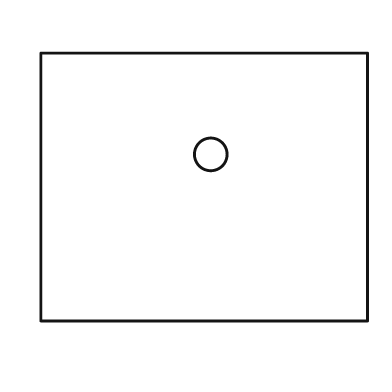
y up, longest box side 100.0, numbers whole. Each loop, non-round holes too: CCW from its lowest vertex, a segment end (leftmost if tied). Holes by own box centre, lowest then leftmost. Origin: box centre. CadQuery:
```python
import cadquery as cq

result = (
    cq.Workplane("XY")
    .moveTo(-50.0, -41.0)
    .lineTo(50.0, -41.0)
    .lineTo(50.0, 41.0)
    .lineTo(-50.0, 41.0)
    .close()
    .moveTo(2.0, 10.0)
    .circle(5.0)
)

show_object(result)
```